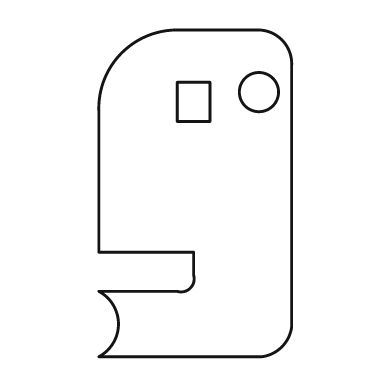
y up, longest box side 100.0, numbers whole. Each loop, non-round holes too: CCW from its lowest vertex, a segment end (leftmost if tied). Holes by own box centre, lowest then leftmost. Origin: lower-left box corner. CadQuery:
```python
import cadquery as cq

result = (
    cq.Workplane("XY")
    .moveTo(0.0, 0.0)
    .lineTo(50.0, 0.0)
    .threePointArc((56.0, 3.0), (59.0, 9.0))
    .lineTo(59.0, 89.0)
    .threePointArc((56.0, 97.0), (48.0, 100.0))
    .lineTo(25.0, 100.0)
    .threePointArc((7.0, 93.0), (0.0, 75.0))
    .lineTo(0.0, 32.0)
    .lineTo(29.0, 32.0)
    .lineTo(29.0, 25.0)
    .threePointArc((28.0, 21.0), (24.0, 20.0))
    .lineTo(0.0, 20.0)
    .threePointArc((6.0, 10.0), (0.0, 0.0))
    .close()
    .moveTo(24.0, 72.0)
    .lineTo(34.0, 72.0)
    .lineTo(34.0, 84.0)
    .lineTo(24.0, 84.0)
    .close()
    .moveTo(49.0, 81.0)
    .circle(6.0)
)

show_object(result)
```